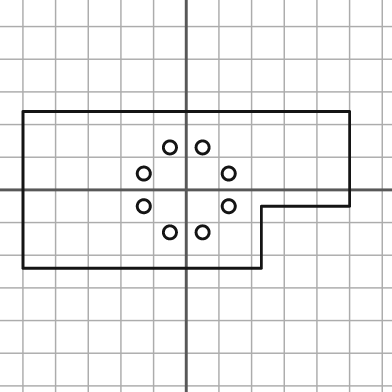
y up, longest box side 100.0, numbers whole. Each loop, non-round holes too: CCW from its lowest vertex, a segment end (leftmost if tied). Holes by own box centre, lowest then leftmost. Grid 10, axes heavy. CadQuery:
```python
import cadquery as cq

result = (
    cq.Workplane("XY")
    .moveTo(-50.0, -24.0)
    .lineTo(23.0, -24.0)
    .lineTo(23.0, -5.0)
    .lineTo(50.0, -5.0)
    .lineTo(50.0, 24.0)
    .lineTo(-50.0, 24.0)
    .close()
    .moveTo(-5.0, -13.0)
    .circle(2.0)
    .moveTo(5.0, -13.0)
    .circle(2.0)
    .moveTo(-13.0, -5.0)
    .circle(2.0)
    .moveTo(13.0, -5.0)
    .circle(2.0)
    .moveTo(-13.0, 5.0)
    .circle(2.0)
    .moveTo(13.0, 5.0)
    .circle(2.0)
    .moveTo(-5.0, 13.0)
    .circle(2.0)
    .moveTo(5.0, 13.0)
    .circle(2.0)
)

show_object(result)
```